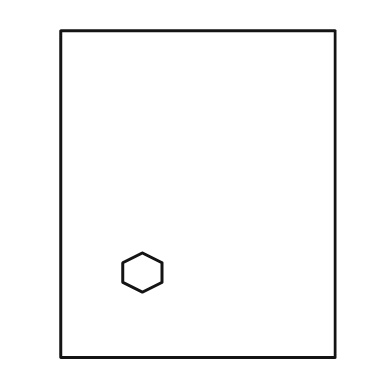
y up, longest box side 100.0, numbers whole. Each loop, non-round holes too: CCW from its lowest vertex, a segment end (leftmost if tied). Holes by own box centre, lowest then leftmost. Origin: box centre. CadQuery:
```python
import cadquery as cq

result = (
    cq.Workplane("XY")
    .moveTo(-42.0, -50.0)
    .lineTo(42.0, -50.0)
    .lineTo(42.0, 50.0)
    .lineTo(-42.0, 50.0)
    .close()
    .moveTo(-17.0, -30.0)
    .lineTo(-11.0, -27.0)
    .lineTo(-11.0, -21.0)
    .lineTo(-17.0, -18.0)
    .lineTo(-23.0, -21.0)
    .lineTo(-23.0, -27.0)
    .close()
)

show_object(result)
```